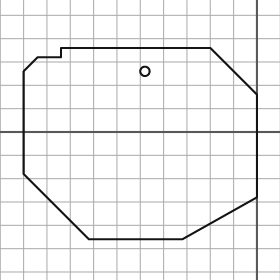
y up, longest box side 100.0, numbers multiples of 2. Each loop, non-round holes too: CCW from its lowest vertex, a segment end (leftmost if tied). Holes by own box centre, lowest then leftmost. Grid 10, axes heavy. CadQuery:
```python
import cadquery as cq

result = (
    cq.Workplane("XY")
    .moveTo(-72.0, -46.0)
    .lineTo(-32.0, -46.0)
    .lineTo(0.0, -28.0)
    .lineTo(0.0, 16.0)
    .lineTo(-20.0, 36.0)
    .lineTo(-84.0, 36.0)
    .lineTo(-84.0, 32.0)
    .lineTo(-94.0, 32.0)
    .lineTo(-100.0, 26.0)
    .lineTo(-100.0, -18.0)
    .close()
    .moveTo(-48.0, 26.0)
    .circle(2.0)
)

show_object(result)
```